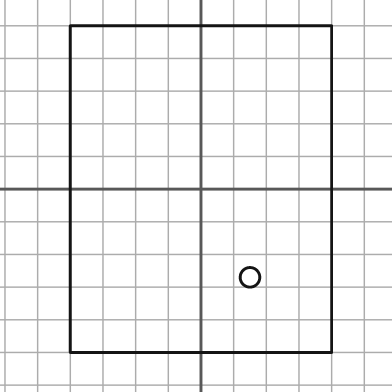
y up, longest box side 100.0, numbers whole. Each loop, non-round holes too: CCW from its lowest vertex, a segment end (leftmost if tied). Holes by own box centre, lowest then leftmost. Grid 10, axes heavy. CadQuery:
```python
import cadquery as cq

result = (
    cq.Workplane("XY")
    .moveTo(-40.0, -50.0)
    .lineTo(40.0, -50.0)
    .lineTo(40.0, 50.0)
    .lineTo(-40.0, 50.0)
    .close()
    .moveTo(15.0, -27.0)
    .circle(3.0)
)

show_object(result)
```